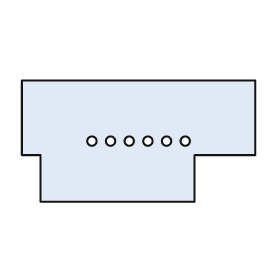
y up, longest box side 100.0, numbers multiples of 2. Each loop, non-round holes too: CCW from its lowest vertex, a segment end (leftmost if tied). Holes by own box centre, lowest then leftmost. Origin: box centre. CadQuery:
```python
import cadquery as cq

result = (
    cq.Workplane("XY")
    .moveTo(-42.0, -26.0)
    .lineTo(24.0, -26.0)
    .lineTo(24.0, -6.0)
    .lineTo(50.0, -6.0)
    .lineTo(50.0, 26.0)
    .lineTo(-50.0, 26.0)
    .lineTo(-50.0, -6.0)
    .lineTo(-42.0, -6.0)
    .close()
    .moveTo(-20.0, 0.0)
    .circle(2.0)
    .moveTo(-12.0, 0.0)
    .circle(2.0)
    .moveTo(-4.0, 0.0)
    .circle(2.0)
    .moveTo(4.0, 0.0)
    .circle(2.0)
    .moveTo(12.0, 0.0)
    .circle(2.0)
    .moveTo(20.0, 0.0)
    .circle(2.0)
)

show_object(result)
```